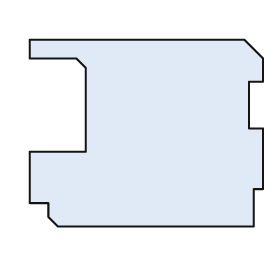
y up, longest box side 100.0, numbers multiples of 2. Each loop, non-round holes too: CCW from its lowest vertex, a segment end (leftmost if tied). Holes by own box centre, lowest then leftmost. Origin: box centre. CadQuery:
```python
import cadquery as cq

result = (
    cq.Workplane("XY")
    .moveTo(-38.0, -40.0)
    .lineTo(46.0, -40.0)
    .lineTo(46.0, -24.0)
    .lineTo(50.0, -24.0)
    .lineTo(50.0, 2.0)
    .lineTo(44.0, 2.0)
    .lineTo(44.0, 22.0)
    .lineTo(50.0, 22.0)
    .lineTo(50.0, 32.0)
    .lineTo(42.0, 40.0)
    .lineTo(-50.0, 40.0)
    .lineTo(-50.0, 32.0)
    .lineTo(-30.0, 32.0)
    .lineTo(-26.0, 28.0)
    .lineTo(-26.0, -8.0)
    .lineTo(-50.0, -8.0)
    .lineTo(-50.0, -30.0)
    .lineTo(-42.0, -30.0)
    .lineTo(-42.0, -36.0)
    .close()
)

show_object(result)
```